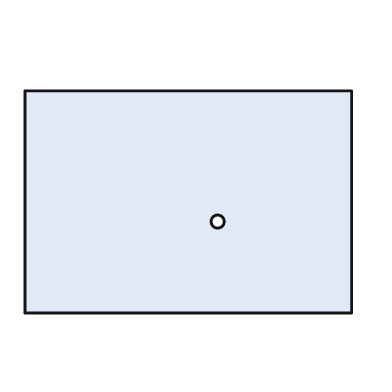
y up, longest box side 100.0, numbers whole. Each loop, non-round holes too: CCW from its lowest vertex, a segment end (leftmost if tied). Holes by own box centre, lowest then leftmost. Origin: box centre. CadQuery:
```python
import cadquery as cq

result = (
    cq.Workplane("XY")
    .moveTo(-50.0, -34.0)
    .lineTo(50.0, -34.0)
    .lineTo(50.0, 34.0)
    .lineTo(-50.0, 34.0)
    .close()
    .moveTo(9.0, -6.0)
    .circle(2.0)
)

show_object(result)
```